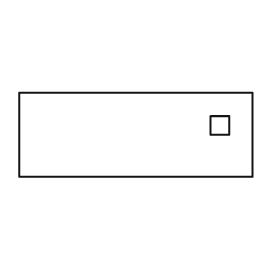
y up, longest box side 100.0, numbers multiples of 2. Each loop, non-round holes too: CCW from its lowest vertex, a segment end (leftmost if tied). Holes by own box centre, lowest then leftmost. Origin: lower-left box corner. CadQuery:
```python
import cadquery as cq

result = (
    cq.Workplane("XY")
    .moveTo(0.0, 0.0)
    .lineTo(100.0, 0.0)
    .lineTo(100.0, 36.0)
    .lineTo(0.0, 36.0)
    .close()
    .moveTo(82.0, 18.0)
    .lineTo(90.0, 18.0)
    .lineTo(90.0, 26.0)
    .lineTo(82.0, 26.0)
    .close()
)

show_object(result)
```